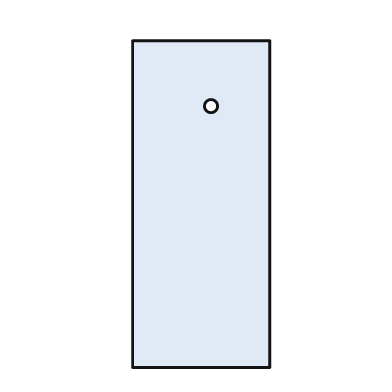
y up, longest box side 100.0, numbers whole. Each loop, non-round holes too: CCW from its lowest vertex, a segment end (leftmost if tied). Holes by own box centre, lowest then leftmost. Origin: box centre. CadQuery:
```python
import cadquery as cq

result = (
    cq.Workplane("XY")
    .moveTo(-21.0, -50.0)
    .lineTo(21.0, -50.0)
    .lineTo(21.0, 50.0)
    .lineTo(-21.0, 50.0)
    .close()
    .moveTo(3.0, 30.0)
    .circle(2.0)
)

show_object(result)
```